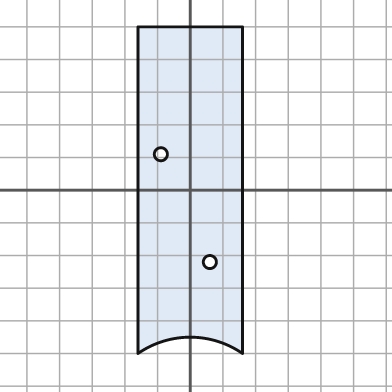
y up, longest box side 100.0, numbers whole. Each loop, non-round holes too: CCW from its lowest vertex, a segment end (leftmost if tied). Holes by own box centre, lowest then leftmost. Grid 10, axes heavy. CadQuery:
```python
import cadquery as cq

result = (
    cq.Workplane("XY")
    .moveTo(-16.0, -50.0)
    .threePointArc((0.0, -45.0), (16.0, -50.0))
    .lineTo(16.0, 50.0)
    .lineTo(-16.0, 50.0)
    .close()
    .moveTo(6.0, -22.0)
    .circle(2.0)
    .moveTo(-9.0, 11.0)
    .circle(2.0)
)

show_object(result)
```